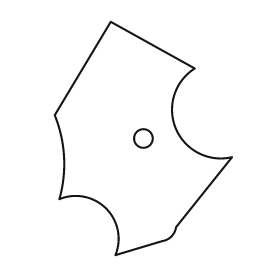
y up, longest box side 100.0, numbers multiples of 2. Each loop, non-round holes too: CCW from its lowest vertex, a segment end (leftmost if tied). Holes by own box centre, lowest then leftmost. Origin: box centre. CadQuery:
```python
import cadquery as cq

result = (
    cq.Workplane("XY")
    .moveTo(-12.0, -50.0)
    .lineTo(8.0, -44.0)
    .threePointArc((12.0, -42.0), (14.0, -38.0))
    .lineTo(38.0, -8.0)
    .threePointArc((14.0, 4.0), (22.0, 30.0))
    .lineTo(-14.0, 50.0)
    .lineTo(-38.0, 10.0)
    .threePointArc((-34.0, -8.0), (-36.0, -26.0))
    .threePointArc((-16.0, -30.0), (-12.0, -50.0))
    .close()
    .moveTo(0.0, 0.0)
    .circle(4.0)
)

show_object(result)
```